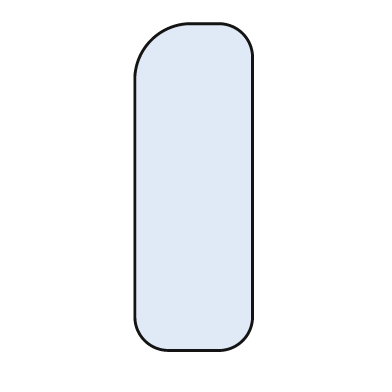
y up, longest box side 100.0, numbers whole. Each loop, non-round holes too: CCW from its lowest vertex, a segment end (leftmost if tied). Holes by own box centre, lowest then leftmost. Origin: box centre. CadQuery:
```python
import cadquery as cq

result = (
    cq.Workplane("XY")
    .moveTo(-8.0, -50.0)
    .lineTo(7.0, -50.0)
    .threePointArc((15.0, -47.0), (18.0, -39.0))
    .lineTo(18.0, 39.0)
    .threePointArc((15.0, 47.0), (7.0, 50.0))
    .lineTo(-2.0, 50.0)
    .threePointArc((-13.0, 45.0), (-18.0, 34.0))
    .lineTo(-18.0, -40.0)
    .threePointArc((-15.0, -47.0), (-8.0, -50.0))
    .close()
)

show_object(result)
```